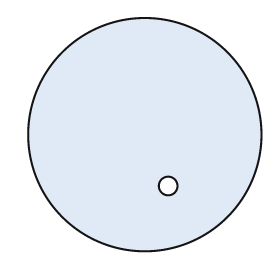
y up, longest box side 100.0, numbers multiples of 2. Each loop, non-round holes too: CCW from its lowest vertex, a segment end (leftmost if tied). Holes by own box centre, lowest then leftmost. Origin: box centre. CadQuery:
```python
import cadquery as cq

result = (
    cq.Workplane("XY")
    .moveTo(0.0, 0.0)
    .circle(50.0)
    .moveTo(10.0, -22.0)
    .circle(4.0)
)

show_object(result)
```